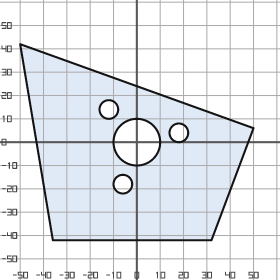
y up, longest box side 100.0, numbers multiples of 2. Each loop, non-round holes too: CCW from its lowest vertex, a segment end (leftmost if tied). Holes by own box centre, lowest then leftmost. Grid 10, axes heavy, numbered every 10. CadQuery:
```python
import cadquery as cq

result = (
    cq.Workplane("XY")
    .moveTo(-36.0, -42.0)
    .lineTo(32.0, -42.0)
    .lineTo(50.0, 6.0)
    .lineTo(-50.0, 42.0)
    .close()
    .moveTo(-6.0, -18.0)
    .circle(4.0)
    .moveTo(0.0, 0.0)
    .circle(10.0)
    .moveTo(18.0, 4.0)
    .circle(4.0)
    .moveTo(-12.0, 14.0)
    .circle(4.0)
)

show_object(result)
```